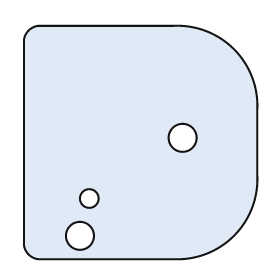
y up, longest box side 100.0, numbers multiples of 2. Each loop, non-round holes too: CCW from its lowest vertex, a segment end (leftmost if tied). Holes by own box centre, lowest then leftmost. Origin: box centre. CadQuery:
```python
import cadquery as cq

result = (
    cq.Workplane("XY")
    .moveTo(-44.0, -50.0)
    .lineTo(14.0, -50.0)
    .threePointArc((40.0, -40.0), (50.0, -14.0))
    .lineTo(50.0, 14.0)
    .threePointArc((40.0, 40.0), (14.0, 50.0))
    .lineTo(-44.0, 50.0)
    .threePointArc((-48.0, 48.0), (-50.0, 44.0))
    .lineTo(-50.0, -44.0)
    .threePointArc((-48.0, -48.0), (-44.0, -50.0))
    .close()
    .moveTo(-26.0, -40.0)
    .circle(6.0)
    .moveTo(-22.0, -24.0)
    .circle(4.0)
    .moveTo(18.0, 2.0)
    .circle(6.0)
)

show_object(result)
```